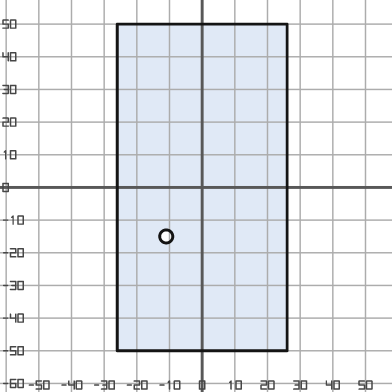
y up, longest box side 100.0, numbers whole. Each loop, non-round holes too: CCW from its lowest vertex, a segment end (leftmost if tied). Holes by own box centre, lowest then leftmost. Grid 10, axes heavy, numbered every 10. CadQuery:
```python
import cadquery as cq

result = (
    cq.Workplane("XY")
    .moveTo(-26.0, -50.0)
    .lineTo(26.0, -50.0)
    .lineTo(26.0, 50.0)
    .lineTo(-26.0, 50.0)
    .close()
    .moveTo(-11.0, -15.0)
    .circle(2.0)
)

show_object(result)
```